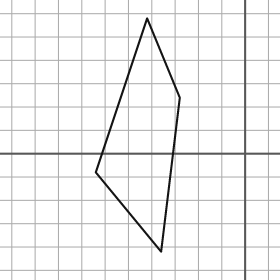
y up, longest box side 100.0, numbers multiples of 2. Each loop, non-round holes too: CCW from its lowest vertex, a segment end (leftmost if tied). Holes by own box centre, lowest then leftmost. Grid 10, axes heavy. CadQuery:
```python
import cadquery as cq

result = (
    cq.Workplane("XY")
    .moveTo(-36.0, -42.0)
    .lineTo(-28.0, 24.0)
    .lineTo(-42.0, 58.0)
    .lineTo(-64.0, -8.0)
    .close()
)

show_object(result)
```